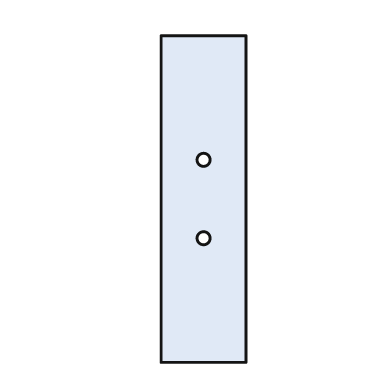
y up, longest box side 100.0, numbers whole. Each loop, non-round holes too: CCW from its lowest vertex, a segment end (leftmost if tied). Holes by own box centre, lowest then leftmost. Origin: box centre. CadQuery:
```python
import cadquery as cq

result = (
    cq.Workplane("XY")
    .moveTo(-13.0, -50.0)
    .lineTo(13.0, -50.0)
    .lineTo(13.0, 50.0)
    .lineTo(-13.0, 50.0)
    .close()
    .moveTo(0.0, -12.0)
    .circle(2.0)
    .moveTo(0.0, 12.0)
    .circle(2.0)
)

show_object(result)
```